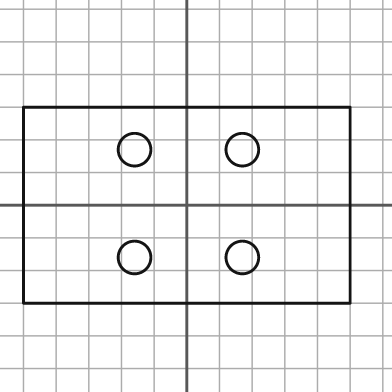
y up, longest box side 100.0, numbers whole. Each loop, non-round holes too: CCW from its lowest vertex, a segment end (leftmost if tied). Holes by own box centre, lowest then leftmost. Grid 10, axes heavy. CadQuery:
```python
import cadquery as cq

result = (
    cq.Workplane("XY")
    .moveTo(-50.0, -30.0)
    .lineTo(50.0, -30.0)
    .lineTo(50.0, 30.0)
    .lineTo(-50.0, 30.0)
    .close()
    .moveTo(-16.0, -16.0)
    .circle(5.0)
    .moveTo(17.0, -16.0)
    .circle(5.0)
    .moveTo(-16.0, 17.0)
    .circle(5.0)
    .moveTo(17.0, 17.0)
    .circle(5.0)
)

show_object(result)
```